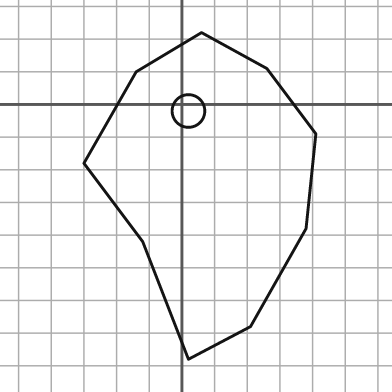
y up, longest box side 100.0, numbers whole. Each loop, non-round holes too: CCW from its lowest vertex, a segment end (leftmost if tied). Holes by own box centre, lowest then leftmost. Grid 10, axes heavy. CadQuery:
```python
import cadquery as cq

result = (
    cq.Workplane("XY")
    .moveTo(2.0, -78.0)
    .lineTo(21.0, -68.0)
    .lineTo(38.0, -38.0)
    .lineTo(41.0, -9.0)
    .lineTo(26.0, 11.0)
    .lineTo(6.0, 22.0)
    .lineTo(-14.0, 10.0)
    .lineTo(-30.0, -18.0)
    .lineTo(-12.0, -42.0)
    .close()
    .moveTo(2.0, -2.0)
    .circle(5.0)
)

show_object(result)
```